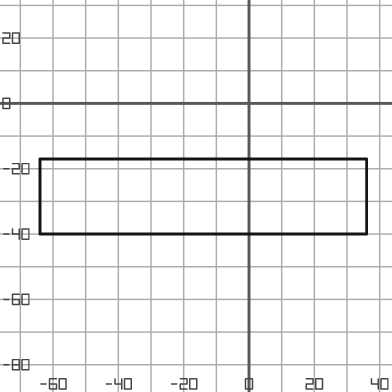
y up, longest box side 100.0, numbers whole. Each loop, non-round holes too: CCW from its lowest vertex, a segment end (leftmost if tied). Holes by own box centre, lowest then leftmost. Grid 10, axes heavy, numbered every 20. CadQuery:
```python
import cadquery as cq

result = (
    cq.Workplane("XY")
    .moveTo(-64.0, -40.0)
    .lineTo(36.0, -40.0)
    .lineTo(36.0, -17.0)
    .lineTo(-64.0, -17.0)
    .close()
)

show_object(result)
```